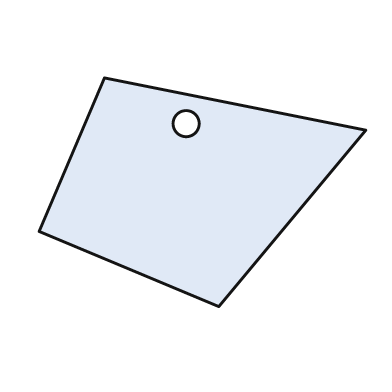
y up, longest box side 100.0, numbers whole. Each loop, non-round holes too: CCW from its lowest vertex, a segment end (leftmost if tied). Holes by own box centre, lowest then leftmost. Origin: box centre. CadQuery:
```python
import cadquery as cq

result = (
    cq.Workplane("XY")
    .moveTo(5.0, -35.0)
    .lineTo(50.0, 19.0)
    .lineTo(-30.0, 35.0)
    .lineTo(-50.0, -12.0)
    .close()
    .moveTo(-5.0, 21.0)
    .circle(4.0)
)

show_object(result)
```